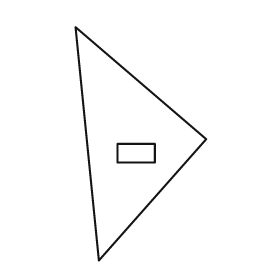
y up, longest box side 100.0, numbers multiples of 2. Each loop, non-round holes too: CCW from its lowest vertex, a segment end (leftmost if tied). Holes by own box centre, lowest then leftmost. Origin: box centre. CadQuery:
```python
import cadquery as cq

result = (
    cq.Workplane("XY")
    .moveTo(-18.0, -50.0)
    .lineTo(28.0, 2.0)
    .lineTo(-28.0, 50.0)
    .close()
    .moveTo(-10.0, -8.0)
    .lineTo(6.0, -8.0)
    .lineTo(6.0, 0.0)
    .lineTo(-10.0, 0.0)
    .close()
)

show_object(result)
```